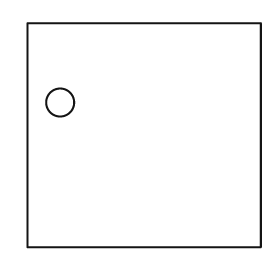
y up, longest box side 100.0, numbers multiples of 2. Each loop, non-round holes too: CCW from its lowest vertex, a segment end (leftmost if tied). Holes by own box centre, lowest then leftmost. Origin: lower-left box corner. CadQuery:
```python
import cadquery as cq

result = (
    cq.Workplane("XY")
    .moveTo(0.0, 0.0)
    .lineTo(100.0, 0.0)
    .lineTo(100.0, 96.0)
    .lineTo(0.0, 96.0)
    .close()
    .moveTo(14.0, 62.0)
    .circle(6.0)
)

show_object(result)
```